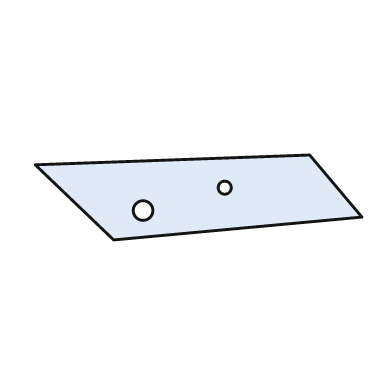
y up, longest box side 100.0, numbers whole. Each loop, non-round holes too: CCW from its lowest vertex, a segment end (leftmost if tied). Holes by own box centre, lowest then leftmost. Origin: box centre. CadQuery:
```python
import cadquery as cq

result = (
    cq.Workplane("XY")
    .moveTo(-26.0, -13.0)
    .lineTo(50.0, -6.0)
    .lineTo(34.0, 13.0)
    .lineTo(-50.0, 10.0)
    .close()
    .moveTo(-17.0, -4.0)
    .circle(3.0)
    .moveTo(8.0, 3.0)
    .circle(2.0)
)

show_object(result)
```